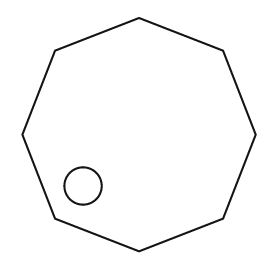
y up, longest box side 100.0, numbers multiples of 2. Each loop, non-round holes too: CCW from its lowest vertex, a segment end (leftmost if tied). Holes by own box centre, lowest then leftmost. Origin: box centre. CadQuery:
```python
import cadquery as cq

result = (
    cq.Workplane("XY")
    .moveTo(0.0, -50.0)
    .lineTo(36.0, -36.0)
    .lineTo(50.0, 0.0)
    .lineTo(36.0, 36.0)
    .lineTo(0.0, 50.0)
    .lineTo(-36.0, 36.0)
    .lineTo(-50.0, 0.0)
    .lineTo(-36.0, -36.0)
    .close()
    .moveTo(-24.0, -22.0)
    .circle(8.0)
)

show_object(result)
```